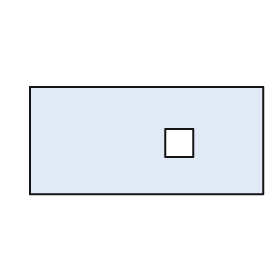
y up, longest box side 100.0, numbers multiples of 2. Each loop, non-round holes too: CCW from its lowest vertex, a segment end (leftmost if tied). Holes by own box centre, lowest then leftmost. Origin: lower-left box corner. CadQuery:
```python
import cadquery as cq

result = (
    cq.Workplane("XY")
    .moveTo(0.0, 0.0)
    .lineTo(100.0, 0.0)
    .lineTo(100.0, 46.0)
    .lineTo(0.0, 46.0)
    .close()
    .moveTo(58.0, 16.0)
    .lineTo(70.0, 16.0)
    .lineTo(70.0, 28.0)
    .lineTo(58.0, 28.0)
    .close()
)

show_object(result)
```